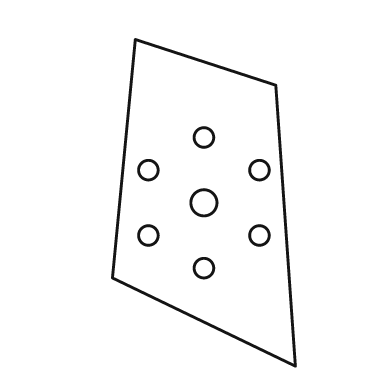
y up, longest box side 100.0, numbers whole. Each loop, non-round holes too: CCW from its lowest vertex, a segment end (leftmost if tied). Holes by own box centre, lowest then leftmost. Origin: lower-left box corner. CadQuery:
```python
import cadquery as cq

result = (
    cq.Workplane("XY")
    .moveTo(56.0, 0.0)
    .lineTo(50.0, 86.0)
    .lineTo(7.0, 100.0)
    .lineTo(0.0, 27.0)
    .close()
    .moveTo(28.0, 30.0)
    .circle(3.0)
    .moveTo(11.0, 40.0)
    .circle(3.0)
    .moveTo(45.0, 40.0)
    .circle(3.0)
    .moveTo(28.0, 50.0)
    .circle(4.0)
    .moveTo(11.0, 60.0)
    .circle(3.0)
    .moveTo(45.0, 60.0)
    .circle(3.0)
    .moveTo(28.0, 70.0)
    .circle(3.0)
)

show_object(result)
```